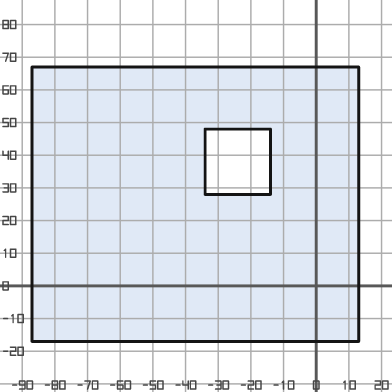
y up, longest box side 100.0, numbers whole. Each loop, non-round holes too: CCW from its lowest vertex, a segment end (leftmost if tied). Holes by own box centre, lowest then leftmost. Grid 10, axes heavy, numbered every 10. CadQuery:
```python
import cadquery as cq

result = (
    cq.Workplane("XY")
    .moveTo(-87.0, -17.0)
    .lineTo(13.0, -17.0)
    .lineTo(13.0, 67.0)
    .lineTo(-87.0, 67.0)
    .close()
    .moveTo(-34.0, 28.0)
    .lineTo(-14.0, 28.0)
    .lineTo(-14.0, 48.0)
    .lineTo(-34.0, 48.0)
    .close()
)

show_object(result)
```